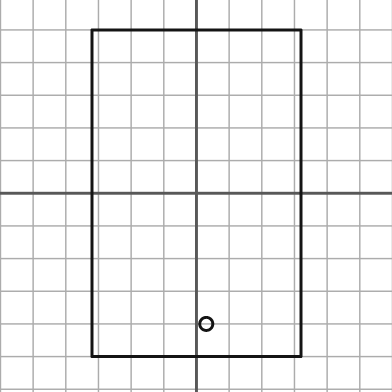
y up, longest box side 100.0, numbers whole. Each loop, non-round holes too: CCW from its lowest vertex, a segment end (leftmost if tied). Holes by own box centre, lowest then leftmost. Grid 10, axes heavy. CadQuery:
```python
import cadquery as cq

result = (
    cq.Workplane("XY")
    .moveTo(-32.0, -50.0)
    .lineTo(32.0, -50.0)
    .lineTo(32.0, 50.0)
    .lineTo(-32.0, 50.0)
    .close()
    .moveTo(3.0, -40.0)
    .circle(2.0)
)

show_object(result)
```